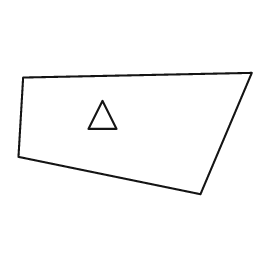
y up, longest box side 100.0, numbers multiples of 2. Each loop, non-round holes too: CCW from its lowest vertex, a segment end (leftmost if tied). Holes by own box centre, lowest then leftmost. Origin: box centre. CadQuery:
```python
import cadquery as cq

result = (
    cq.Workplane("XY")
    .moveTo(28.0, -26.0)
    .lineTo(50.0, 26.0)
    .lineTo(-48.0, 24.0)
    .lineTo(-50.0, -10.0)
    .close()
    .moveTo(-20.0, 2.0)
    .lineTo(-8.0, 2.0)
    .lineTo(-14.0, 14.0)
    .close()
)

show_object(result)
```